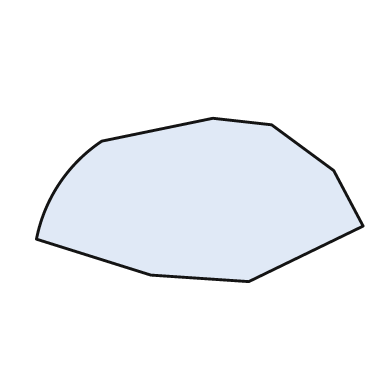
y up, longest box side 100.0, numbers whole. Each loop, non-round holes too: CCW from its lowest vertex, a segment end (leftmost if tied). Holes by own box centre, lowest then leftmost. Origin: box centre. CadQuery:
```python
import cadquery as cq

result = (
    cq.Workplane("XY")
    .moveTo(15.0, -25.0)
    .lineTo(50.0, -8.0)
    .lineTo(41.0, 9.0)
    .lineTo(22.0, 23.0)
    .lineTo(4.0, 25.0)
    .lineTo(-30.0, 18.0)
    .threePointArc((-43.0, 5.0), (-50.0, -12.0))
    .lineTo(-15.0, -23.0)
    .close()
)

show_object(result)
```